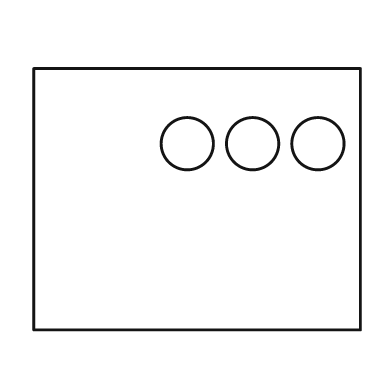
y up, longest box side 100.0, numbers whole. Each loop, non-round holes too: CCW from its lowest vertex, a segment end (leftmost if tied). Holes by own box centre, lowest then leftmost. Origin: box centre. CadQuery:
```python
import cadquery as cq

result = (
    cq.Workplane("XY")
    .moveTo(-50.0, -40.0)
    .lineTo(50.0, -40.0)
    .lineTo(50.0, 40.0)
    .lineTo(-50.0, 40.0)
    .close()
    .moveTo(-3.0, 17.0)
    .circle(8.0)
    .moveTo(17.0, 17.0)
    .circle(8.0)
    .moveTo(37.0, 17.0)
    .circle(8.0)
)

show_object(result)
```